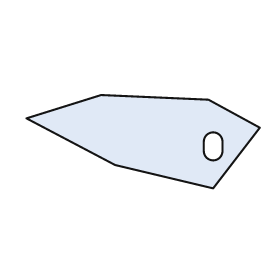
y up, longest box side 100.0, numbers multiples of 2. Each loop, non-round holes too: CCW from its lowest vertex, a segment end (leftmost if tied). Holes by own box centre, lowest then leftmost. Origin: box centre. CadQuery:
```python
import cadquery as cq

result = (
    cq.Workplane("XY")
    .moveTo(30.0, -20.0)
    .lineTo(50.0, 6.0)
    .lineTo(28.0, 18.0)
    .lineTo(-18.0, 20.0)
    .lineTo(-50.0, 10.0)
    .lineTo(-12.0, -10.0)
    .close()
    .moveTo(26.0, -4.0)
    .threePointArc((30.0, -8.0), (34.0, -4.0))
    .lineTo(34.0, 0.0)
    .threePointArc((30.0, 4.0), (26.0, 0.0))
    .close()
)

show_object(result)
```